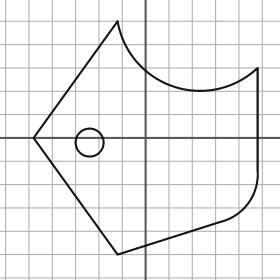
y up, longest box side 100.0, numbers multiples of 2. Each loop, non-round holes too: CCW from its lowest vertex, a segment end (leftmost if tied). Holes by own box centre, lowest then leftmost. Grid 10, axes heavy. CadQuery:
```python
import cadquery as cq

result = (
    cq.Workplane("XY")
    .moveTo(-12.0, -50.0)
    .lineTo(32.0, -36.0)
    .threePointArc((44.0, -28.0), (48.0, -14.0))
    .lineTo(48.0, 30.0)
    .threePointArc((12.0, 22.0), (-12.0, 50.0))
    .lineTo(-48.0, 0.0)
    .close()
    .moveTo(-24.0, -2.0)
    .circle(6.0)
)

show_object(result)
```